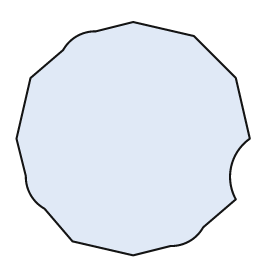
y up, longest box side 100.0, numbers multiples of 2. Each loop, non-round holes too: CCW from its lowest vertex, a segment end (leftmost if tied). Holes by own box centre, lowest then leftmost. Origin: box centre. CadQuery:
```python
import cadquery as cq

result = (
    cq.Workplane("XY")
    .moveTo(0.0, -50.0)
    .lineTo(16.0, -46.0)
    .threePointArc((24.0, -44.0), (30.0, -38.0))
    .lineTo(44.0, -26.0)
    .threePointArc((42.0, -12.0), (50.0, 0.0))
    .lineTo(44.0, 26.0)
    .lineTo(26.0, 44.0)
    .lineTo(0.0, 50.0)
    .lineTo(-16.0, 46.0)
    .threePointArc((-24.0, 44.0), (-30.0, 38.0))
    .lineTo(-44.0, 26.0)
    .lineTo(-50.0, 0.0)
    .lineTo(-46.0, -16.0)
    .threePointArc((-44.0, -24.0), (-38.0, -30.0))
    .lineTo(-26.0, -44.0)
    .close()
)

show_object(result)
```